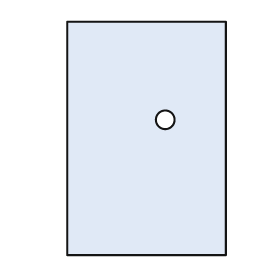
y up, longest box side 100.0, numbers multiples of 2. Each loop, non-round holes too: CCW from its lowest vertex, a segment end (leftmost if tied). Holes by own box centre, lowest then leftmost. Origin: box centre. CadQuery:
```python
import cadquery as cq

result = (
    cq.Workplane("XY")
    .moveTo(-34.0, -50.0)
    .lineTo(34.0, -50.0)
    .lineTo(34.0, 50.0)
    .lineTo(-34.0, 50.0)
    .close()
    .moveTo(8.0, 8.0)
    .circle(4.0)
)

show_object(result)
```